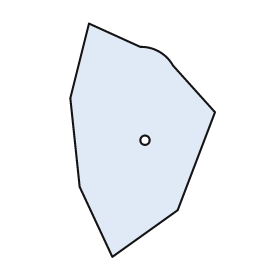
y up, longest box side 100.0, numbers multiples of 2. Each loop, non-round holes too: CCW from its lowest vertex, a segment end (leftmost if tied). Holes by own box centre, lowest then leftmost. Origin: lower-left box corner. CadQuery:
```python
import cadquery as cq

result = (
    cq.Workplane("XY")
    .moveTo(18.0, 0.0)
    .lineTo(46.0, 20.0)
    .lineTo(62.0, 62.0)
    .lineTo(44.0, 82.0)
    .threePointArc((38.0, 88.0), (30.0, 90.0))
    .lineTo(8.0, 100.0)
    .lineTo(0.0, 68.0)
    .lineTo(4.0, 30.0)
    .close()
    .moveTo(32.0, 50.0)
    .circle(2.0)
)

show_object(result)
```